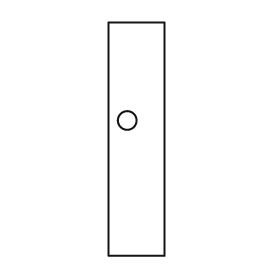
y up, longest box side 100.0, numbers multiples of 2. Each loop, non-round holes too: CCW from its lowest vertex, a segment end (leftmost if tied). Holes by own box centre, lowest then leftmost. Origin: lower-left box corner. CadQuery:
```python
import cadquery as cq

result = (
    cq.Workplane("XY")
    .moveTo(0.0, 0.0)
    .lineTo(24.0, 0.0)
    .lineTo(24.0, 100.0)
    .lineTo(0.0, 100.0)
    .close()
    .moveTo(8.0, 58.0)
    .circle(4.0)
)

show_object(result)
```